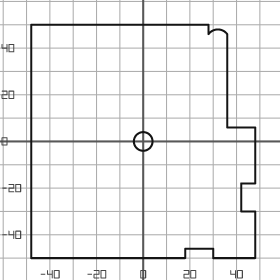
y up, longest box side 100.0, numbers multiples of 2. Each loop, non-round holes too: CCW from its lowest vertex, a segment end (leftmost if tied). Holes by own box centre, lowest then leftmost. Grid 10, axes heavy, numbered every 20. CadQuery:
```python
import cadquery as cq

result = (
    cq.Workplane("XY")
    .moveTo(-48.0, -50.0)
    .lineTo(18.0, -50.0)
    .lineTo(18.0, -46.0)
    .lineTo(30.0, -46.0)
    .lineTo(30.0, -50.0)
    .lineTo(48.0, -50.0)
    .lineTo(48.0, -30.0)
    .lineTo(42.0, -30.0)
    .lineTo(42.0, -18.0)
    .lineTo(48.0, -18.0)
    .lineTo(48.0, 6.0)
    .lineTo(36.0, 6.0)
    .lineTo(36.0, 46.0)
    .threePointArc((32.0, 48.0), (28.0, 46.0))
    .lineTo(28.0, 50.0)
    .lineTo(-48.0, 50.0)
    .close()
    .moveTo(0.0, 0.0)
    .circle(4.0)
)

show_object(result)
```